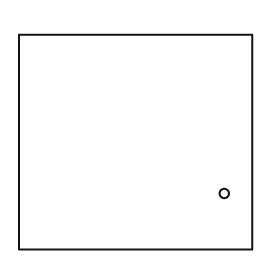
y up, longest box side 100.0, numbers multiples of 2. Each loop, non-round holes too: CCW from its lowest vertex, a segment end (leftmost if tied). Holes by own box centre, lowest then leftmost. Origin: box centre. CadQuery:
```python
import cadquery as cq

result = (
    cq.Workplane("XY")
    .moveTo(-50.0, -46.0)
    .lineTo(50.0, -46.0)
    .lineTo(50.0, 46.0)
    .lineTo(-50.0, 46.0)
    .close()
    .moveTo(38.0, -22.0)
    .circle(2.0)
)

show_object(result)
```